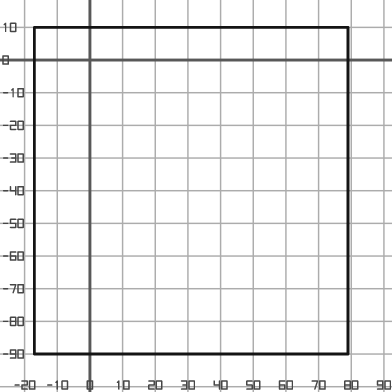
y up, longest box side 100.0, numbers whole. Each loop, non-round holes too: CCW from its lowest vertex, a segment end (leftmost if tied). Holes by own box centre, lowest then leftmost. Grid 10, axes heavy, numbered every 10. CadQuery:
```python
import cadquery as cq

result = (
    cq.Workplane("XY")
    .moveTo(-17.0, -90.0)
    .lineTo(79.0, -90.0)
    .lineTo(79.0, 10.0)
    .lineTo(-17.0, 10.0)
    .close()
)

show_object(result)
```